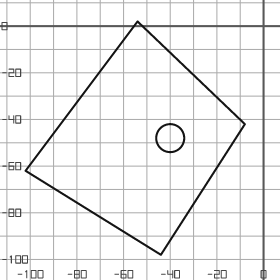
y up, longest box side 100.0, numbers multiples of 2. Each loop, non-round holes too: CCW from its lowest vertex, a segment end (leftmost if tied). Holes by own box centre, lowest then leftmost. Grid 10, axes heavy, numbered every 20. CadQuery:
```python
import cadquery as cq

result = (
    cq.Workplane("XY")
    .moveTo(-44.0, -98.0)
    .lineTo(-8.0, -42.0)
    .lineTo(-54.0, 2.0)
    .lineTo(-102.0, -62.0)
    .close()
    .moveTo(-40.0, -48.0)
    .circle(6.0)
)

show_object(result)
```